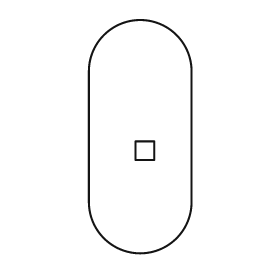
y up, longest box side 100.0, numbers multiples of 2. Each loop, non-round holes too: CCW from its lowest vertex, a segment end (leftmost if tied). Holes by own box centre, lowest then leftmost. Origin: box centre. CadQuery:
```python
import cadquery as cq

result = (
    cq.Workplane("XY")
    .moveTo(-22.0, -28.0)
    .threePointArc((0.0, -50.0), (22.0, -28.0))
    .lineTo(22.0, 28.0)
    .threePointArc((0.0, 50.0), (-22.0, 28.0))
    .close()
    .moveTo(-2.0, -10.0)
    .lineTo(6.0, -10.0)
    .lineTo(6.0, -2.0)
    .lineTo(-2.0, -2.0)
    .close()
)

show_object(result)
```